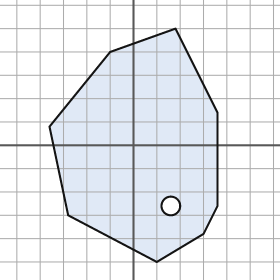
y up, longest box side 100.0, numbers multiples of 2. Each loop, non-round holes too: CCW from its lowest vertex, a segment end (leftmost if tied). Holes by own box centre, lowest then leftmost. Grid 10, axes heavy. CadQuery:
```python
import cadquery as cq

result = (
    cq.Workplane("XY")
    .moveTo(10.0, -50.0)
    .lineTo(30.0, -38.0)
    .lineTo(36.0, -26.0)
    .lineTo(36.0, 14.0)
    .lineTo(18.0, 50.0)
    .lineTo(-10.0, 40.0)
    .lineTo(-36.0, 8.0)
    .lineTo(-28.0, -30.0)
    .close()
    .moveTo(16.0, -26.0)
    .circle(4.0)
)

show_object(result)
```